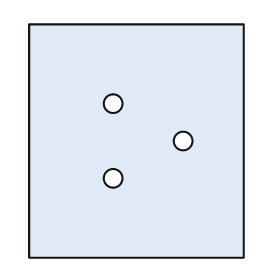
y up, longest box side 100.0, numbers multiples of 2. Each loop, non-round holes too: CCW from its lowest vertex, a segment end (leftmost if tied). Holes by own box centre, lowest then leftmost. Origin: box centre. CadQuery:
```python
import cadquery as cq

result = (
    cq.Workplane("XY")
    .moveTo(-46.0, -50.0)
    .lineTo(46.0, -50.0)
    .lineTo(46.0, 50.0)
    .lineTo(-46.0, 50.0)
    .close()
    .moveTo(-10.0, -16.0)
    .circle(4.0)
    .moveTo(20.0, 0.0)
    .circle(4.0)
    .moveTo(-10.0, 16.0)
    .circle(4.0)
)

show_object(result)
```